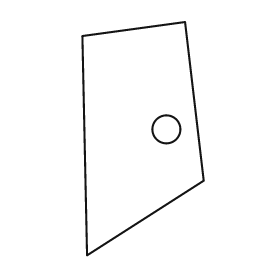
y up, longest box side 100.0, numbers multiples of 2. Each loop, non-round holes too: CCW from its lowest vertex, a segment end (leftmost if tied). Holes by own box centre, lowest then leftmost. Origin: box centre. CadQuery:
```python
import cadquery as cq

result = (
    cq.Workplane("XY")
    .moveTo(-24.0, -50.0)
    .lineTo(26.0, -18.0)
    .lineTo(18.0, 50.0)
    .lineTo(-26.0, 44.0)
    .close()
    .moveTo(10.0, 4.0)
    .circle(6.0)
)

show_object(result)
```